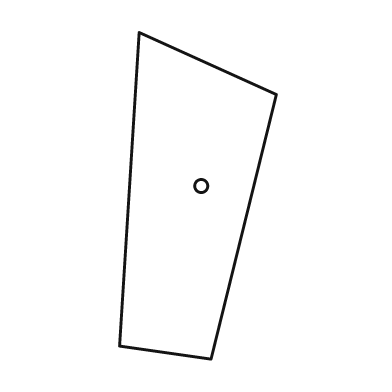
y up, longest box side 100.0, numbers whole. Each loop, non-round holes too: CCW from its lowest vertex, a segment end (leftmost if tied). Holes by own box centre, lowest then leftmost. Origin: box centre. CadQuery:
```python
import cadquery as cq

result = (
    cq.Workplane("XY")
    .moveTo(4.0, -50.0)
    .lineTo(24.0, 31.0)
    .lineTo(-18.0, 50.0)
    .lineTo(-24.0, -46.0)
    .close()
    .moveTo(1.0, 3.0)
    .circle(2.0)
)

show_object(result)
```